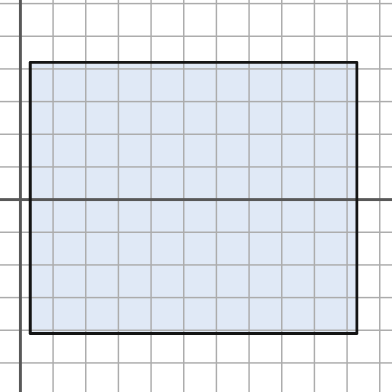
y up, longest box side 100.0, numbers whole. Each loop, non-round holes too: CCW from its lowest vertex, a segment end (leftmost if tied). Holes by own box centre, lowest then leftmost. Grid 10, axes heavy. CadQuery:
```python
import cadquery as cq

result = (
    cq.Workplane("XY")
    .moveTo(3.0, -41.0)
    .lineTo(103.0, -41.0)
    .lineTo(103.0, 42.0)
    .lineTo(3.0, 42.0)
    .close()
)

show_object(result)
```